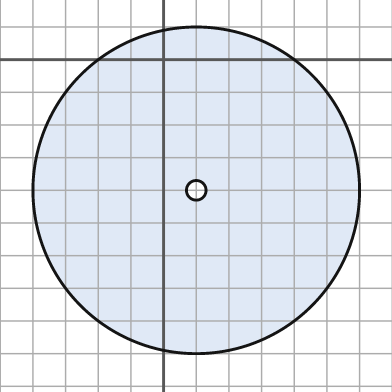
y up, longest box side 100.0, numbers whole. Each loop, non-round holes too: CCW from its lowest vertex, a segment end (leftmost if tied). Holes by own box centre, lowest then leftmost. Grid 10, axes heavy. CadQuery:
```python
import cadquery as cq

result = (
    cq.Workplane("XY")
    .moveTo(10.0, -40.0)
    .circle(50.0)
    .moveTo(10.0, -40.0)
    .circle(3.0)
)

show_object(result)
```